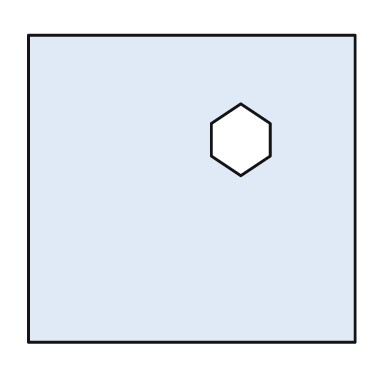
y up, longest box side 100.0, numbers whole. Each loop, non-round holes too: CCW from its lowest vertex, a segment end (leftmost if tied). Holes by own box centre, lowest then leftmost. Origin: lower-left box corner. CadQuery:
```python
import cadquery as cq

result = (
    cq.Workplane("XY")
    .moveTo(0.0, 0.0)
    .lineTo(100.0, 0.0)
    .lineTo(100.0, 94.0)
    .lineTo(0.0, 94.0)
    .close()
    .moveTo(65.0, 51.0)
    .lineTo(74.0, 57.0)
    .lineTo(74.0, 67.0)
    .lineTo(65.0, 73.0)
    .lineTo(56.0, 67.0)
    .lineTo(56.0, 57.0)
    .close()
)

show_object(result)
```